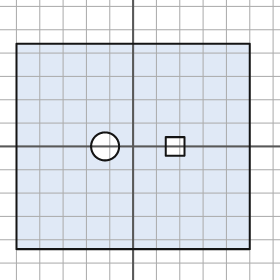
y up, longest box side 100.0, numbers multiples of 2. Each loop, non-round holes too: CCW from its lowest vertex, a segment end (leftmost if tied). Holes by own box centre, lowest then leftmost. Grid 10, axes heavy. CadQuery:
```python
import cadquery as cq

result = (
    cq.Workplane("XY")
    .moveTo(-50.0, -44.0)
    .lineTo(50.0, -44.0)
    .lineTo(50.0, 44.0)
    .lineTo(-50.0, 44.0)
    .close()
    .moveTo(-12.0, 0.0)
    .circle(6.0)
    .moveTo(14.0, -4.0)
    .lineTo(22.0, -4.0)
    .lineTo(22.0, 4.0)
    .lineTo(14.0, 4.0)
    .close()
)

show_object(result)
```